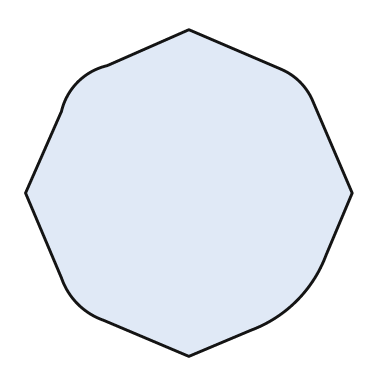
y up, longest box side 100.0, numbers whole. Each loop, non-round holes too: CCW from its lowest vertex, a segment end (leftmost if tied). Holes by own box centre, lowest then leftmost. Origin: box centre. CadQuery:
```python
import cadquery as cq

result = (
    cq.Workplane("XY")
    .moveTo(0.0, -50.0)
    .lineTo(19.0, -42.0)
    .threePointArc((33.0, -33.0), (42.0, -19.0))
    .lineTo(50.0, 0.0)
    .lineTo(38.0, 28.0)
    .threePointArc((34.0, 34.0), (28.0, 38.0))
    .lineTo(0.0, 50.0)
    .lineTo(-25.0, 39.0)
    .threePointArc((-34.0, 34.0), (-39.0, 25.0))
    .lineTo(-50.0, 0.0)
    .lineTo(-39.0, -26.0)
    .threePointArc((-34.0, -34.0), (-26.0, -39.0))
    .close()
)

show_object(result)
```